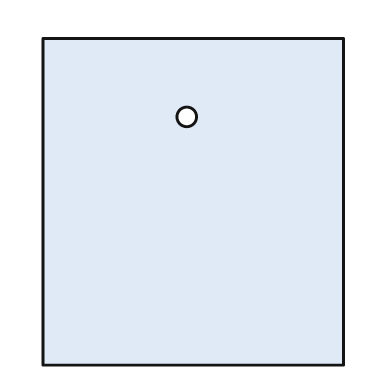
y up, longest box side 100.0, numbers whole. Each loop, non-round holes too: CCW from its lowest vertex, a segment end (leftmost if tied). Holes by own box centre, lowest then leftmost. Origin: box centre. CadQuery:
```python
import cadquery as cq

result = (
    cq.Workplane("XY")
    .moveTo(-46.0, -50.0)
    .lineTo(46.0, -50.0)
    .lineTo(46.0, 50.0)
    .lineTo(-46.0, 50.0)
    .close()
    .moveTo(-2.0, 26.0)
    .circle(3.0)
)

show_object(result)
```